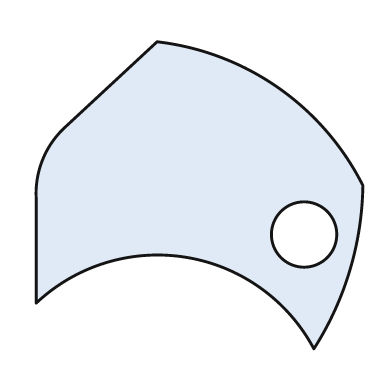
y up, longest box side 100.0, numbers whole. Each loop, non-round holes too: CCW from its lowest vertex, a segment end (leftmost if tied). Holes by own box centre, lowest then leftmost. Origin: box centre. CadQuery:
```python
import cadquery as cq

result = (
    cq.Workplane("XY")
    .moveTo(35.0, -47.0)
    .threePointArc((46.0, -23.0), (50.0, 3.0))
    .threePointArc((24.0, 33.0), (-13.0, 47.0))
    .lineTo(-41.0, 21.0)
    .threePointArc((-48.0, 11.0), (-50.0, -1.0))
    .lineTo(-50.0, -33.0)
    .threePointArc((-4.0, -19.0), (35.0, -47.0))
    .close()
    .moveTo(32.0, -12.0)
    .circle(10.0)
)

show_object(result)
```